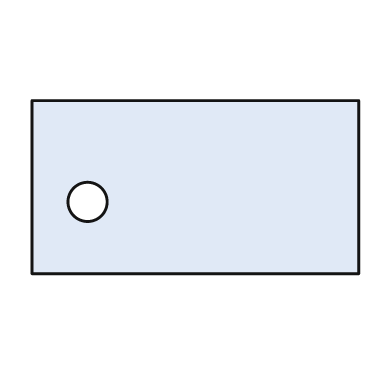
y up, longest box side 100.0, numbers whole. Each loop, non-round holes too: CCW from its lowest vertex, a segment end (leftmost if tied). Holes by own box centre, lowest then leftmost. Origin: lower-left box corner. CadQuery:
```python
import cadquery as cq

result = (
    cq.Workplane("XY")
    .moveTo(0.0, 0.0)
    .lineTo(100.0, 0.0)
    .lineTo(100.0, 53.0)
    .lineTo(0.0, 53.0)
    .close()
    .moveTo(17.0, 22.0)
    .circle(6.0)
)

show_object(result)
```